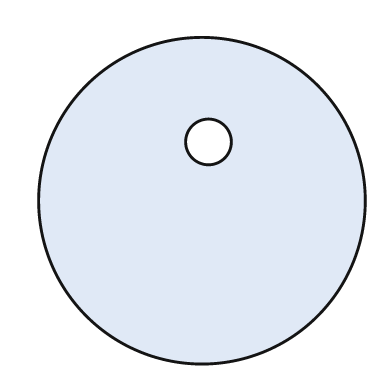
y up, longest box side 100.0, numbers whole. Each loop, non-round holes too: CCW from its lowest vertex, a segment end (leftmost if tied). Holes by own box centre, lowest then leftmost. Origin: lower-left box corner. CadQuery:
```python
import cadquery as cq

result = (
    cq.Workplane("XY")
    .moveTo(50.0, 50.0)
    .circle(50.0)
    .moveTo(52.0, 68.0)
    .circle(7.0)
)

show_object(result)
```